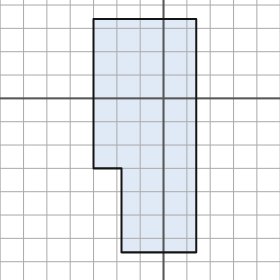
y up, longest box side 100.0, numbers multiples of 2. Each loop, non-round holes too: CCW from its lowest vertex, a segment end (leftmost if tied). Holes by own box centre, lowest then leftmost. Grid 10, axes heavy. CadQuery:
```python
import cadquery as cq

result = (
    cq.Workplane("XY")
    .moveTo(-18.0, -66.0)
    .lineTo(14.0, -66.0)
    .lineTo(14.0, 34.0)
    .lineTo(-30.0, 34.0)
    .lineTo(-30.0, -30.0)
    .lineTo(-18.0, -30.0)
    .close()
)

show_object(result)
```